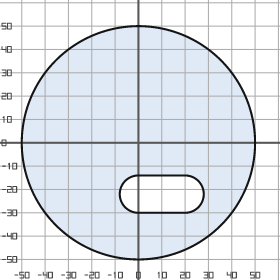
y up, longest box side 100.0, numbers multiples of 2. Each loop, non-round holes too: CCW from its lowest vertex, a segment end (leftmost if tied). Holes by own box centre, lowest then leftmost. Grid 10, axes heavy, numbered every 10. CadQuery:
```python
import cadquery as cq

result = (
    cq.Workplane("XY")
    .moveTo(0.0, 0.0)
    .circle(50.0)
    .moveTo(0.0, -30.0)
    .lineTo(20.0, -30.0)
    .threePointArc((28.0, -22.0), (20.0, -14.0))
    .lineTo(0.0, -14.0)
    .threePointArc((-8.0, -22.0), (0.0, -30.0))
    .close()
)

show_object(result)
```